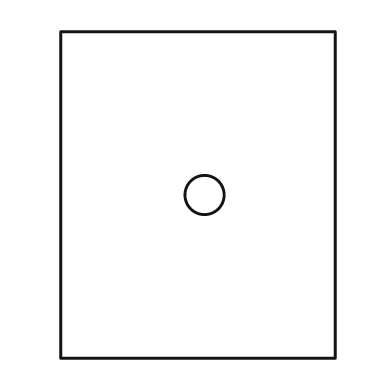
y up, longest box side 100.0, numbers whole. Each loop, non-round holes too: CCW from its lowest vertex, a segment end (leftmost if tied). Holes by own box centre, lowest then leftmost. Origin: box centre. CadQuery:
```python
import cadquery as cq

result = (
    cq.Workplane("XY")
    .moveTo(-42.0, -50.0)
    .lineTo(42.0, -50.0)
    .lineTo(42.0, 50.0)
    .lineTo(-42.0, 50.0)
    .close()
    .moveTo(2.0, 0.0)
    .circle(6.0)
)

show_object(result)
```